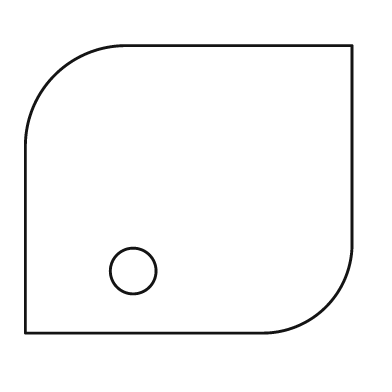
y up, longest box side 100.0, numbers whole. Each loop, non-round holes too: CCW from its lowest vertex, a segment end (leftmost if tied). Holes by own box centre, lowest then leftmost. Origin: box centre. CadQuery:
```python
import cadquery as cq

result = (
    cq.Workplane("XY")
    .moveTo(-50.0, -44.0)
    .lineTo(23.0, -44.0)
    .threePointArc((42.0, -36.0), (50.0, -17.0))
    .lineTo(50.0, 44.0)
    .lineTo(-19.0, 44.0)
    .threePointArc((-41.0, 35.0), (-50.0, 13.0))
    .close()
    .moveTo(-17.0, -25.0)
    .circle(7.0)
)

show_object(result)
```